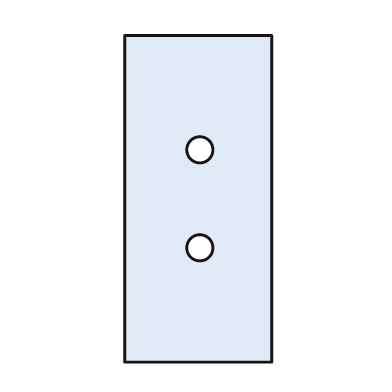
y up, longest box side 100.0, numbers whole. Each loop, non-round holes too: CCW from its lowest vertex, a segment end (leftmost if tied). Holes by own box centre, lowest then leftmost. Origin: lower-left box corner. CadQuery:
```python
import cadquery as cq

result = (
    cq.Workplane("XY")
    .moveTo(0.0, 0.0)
    .lineTo(45.0, 0.0)
    .lineTo(45.0, 100.0)
    .lineTo(0.0, 100.0)
    .close()
    .moveTo(23.0, 35.0)
    .circle(4.0)
    .moveTo(23.0, 65.0)
    .circle(4.0)
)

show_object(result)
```